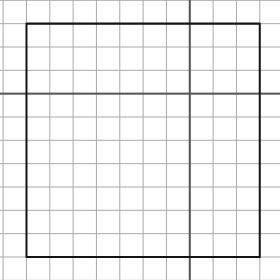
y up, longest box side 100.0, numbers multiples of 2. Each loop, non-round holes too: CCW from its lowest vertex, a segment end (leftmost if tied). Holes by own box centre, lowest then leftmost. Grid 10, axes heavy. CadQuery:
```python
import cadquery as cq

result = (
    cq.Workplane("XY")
    .moveTo(-70.0, -70.0)
    .lineTo(30.0, -70.0)
    .lineTo(30.0, 30.0)
    .lineTo(-70.0, 30.0)
    .close()
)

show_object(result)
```